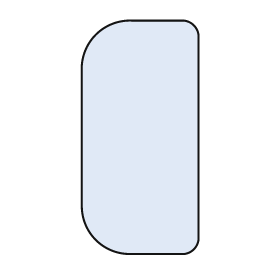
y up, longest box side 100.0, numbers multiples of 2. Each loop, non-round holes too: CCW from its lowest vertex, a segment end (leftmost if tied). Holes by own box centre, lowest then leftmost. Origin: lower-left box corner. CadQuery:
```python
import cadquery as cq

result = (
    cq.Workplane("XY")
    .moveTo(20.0, 0.0)
    .lineTo(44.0, 0.0)
    .threePointArc((48.0, 2.0), (50.0, 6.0))
    .lineTo(50.0, 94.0)
    .threePointArc((48.0, 98.0), (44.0, 100.0))
    .lineTo(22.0, 100.0)
    .threePointArc((6.0, 94.0), (0.0, 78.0))
    .lineTo(0.0, 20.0)
    .threePointArc((6.0, 6.0), (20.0, 0.0))
    .close()
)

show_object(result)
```